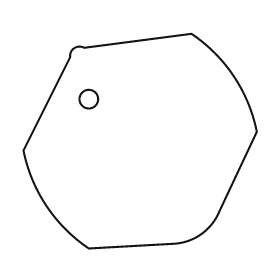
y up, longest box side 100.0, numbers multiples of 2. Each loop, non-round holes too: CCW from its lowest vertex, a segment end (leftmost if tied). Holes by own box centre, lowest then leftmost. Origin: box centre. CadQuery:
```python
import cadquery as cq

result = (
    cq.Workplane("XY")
    .moveTo(-22.0, -46.0)
    .lineTo(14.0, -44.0)
    .threePointArc((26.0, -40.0), (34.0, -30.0))
    .lineTo(50.0, 4.0)
    .threePointArc((40.0, 28.0), (22.0, 46.0))
    .lineTo(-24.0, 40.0)
    .threePointArc((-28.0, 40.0), (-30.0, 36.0))
    .lineTo(-50.0, -4.0)
    .threePointArc((-40.0, -28.0), (-22.0, -46.0))
    .close()
    .moveTo(-22.0, 18.0)
    .circle(4.0)
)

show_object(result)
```